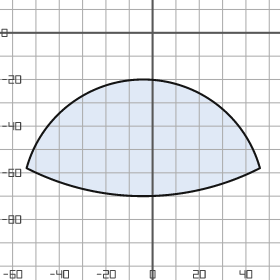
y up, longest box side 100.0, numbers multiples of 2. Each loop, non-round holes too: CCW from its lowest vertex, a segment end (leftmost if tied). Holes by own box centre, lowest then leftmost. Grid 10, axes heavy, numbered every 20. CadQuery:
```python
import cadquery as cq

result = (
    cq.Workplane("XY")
    .moveTo(-54.0, -58.0)
    .threePointArc((-4.0, -70.0), (46.0, -58.0))
    .threePointArc((-4.0, -20.0), (-54.0, -58.0))
    .close()
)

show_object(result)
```